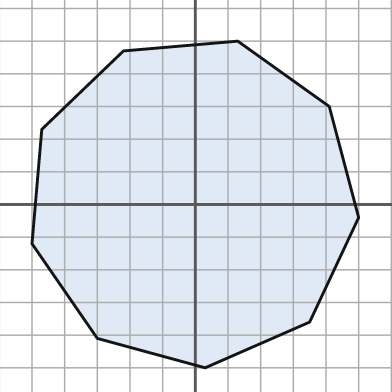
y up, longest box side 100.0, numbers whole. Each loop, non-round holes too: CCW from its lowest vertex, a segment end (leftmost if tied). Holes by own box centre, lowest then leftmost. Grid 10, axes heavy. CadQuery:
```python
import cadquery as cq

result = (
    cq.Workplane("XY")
    .moveTo(3.0, -50.0)
    .lineTo(35.0, -36.0)
    .lineTo(50.0, -4.0)
    .lineTo(41.0, 30.0)
    .lineTo(13.0, 50.0)
    .lineTo(-22.0, 47.0)
    .lineTo(-47.0, 23.0)
    .lineTo(-50.0, -12.0)
    .lineTo(-30.0, -41.0)
    .close()
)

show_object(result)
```